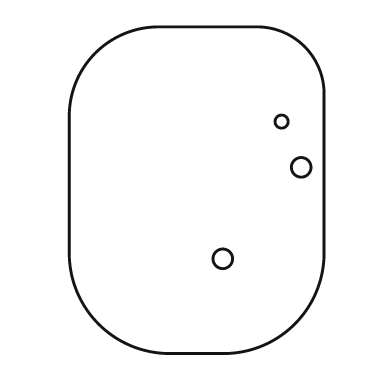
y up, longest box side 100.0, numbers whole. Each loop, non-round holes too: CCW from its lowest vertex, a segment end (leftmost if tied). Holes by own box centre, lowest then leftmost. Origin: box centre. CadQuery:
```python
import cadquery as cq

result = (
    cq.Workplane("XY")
    .moveTo(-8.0, -50.0)
    .lineTo(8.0, -50.0)
    .threePointArc((30.0, -41.0), (39.0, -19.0))
    .lineTo(39.0, 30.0)
    .threePointArc((33.0, 44.0), (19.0, 50.0))
    .lineTo(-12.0, 50.0)
    .threePointArc((-31.0, 42.0), (-39.0, 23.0))
    .lineTo(-39.0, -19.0)
    .threePointArc((-30.0, -41.0), (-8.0, -50.0))
    .close()
    .moveTo(8.0, -21.0)
    .circle(3.0)
    .moveTo(32.0, 7.0)
    .circle(3.0)
    .moveTo(26.0, 21.0)
    .circle(2.0)
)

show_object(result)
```